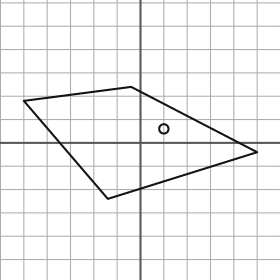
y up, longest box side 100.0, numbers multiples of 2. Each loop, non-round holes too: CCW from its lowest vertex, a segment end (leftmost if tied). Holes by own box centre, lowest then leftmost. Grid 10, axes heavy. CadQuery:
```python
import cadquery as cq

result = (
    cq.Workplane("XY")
    .moveTo(-14.0, -24.0)
    .lineTo(50.0, -4.0)
    .lineTo(-4.0, 24.0)
    .lineTo(-50.0, 18.0)
    .close()
    .moveTo(10.0, 6.0)
    .circle(2.0)
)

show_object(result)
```